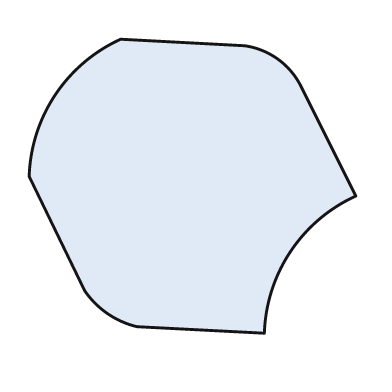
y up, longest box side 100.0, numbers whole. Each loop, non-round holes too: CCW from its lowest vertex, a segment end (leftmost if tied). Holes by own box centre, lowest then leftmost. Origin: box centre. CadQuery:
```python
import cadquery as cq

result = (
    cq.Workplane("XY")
    .moveTo(22.0, -45.0)
    .threePointArc((30.0, -20.0), (50.0, -3.0))
    .lineTo(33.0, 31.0)
    .threePointArc((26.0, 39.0), (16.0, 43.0))
    .lineTo(-22.0, 45.0)
    .threePointArc((-42.0, 28.0), (-50.0, 3.0))
    .lineTo(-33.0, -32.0)
    .threePointArc((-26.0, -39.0), (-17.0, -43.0))
    .close()
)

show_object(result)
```